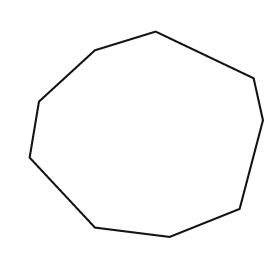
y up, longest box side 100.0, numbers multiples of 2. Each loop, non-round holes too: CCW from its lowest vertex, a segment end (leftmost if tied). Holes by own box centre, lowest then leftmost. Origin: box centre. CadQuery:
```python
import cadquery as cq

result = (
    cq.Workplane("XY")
    .moveTo(10.0, -44.0)
    .lineTo(40.0, -32.0)
    .lineTo(50.0, 6.0)
    .lineTo(46.0, 24.0)
    .lineTo(4.0, 44.0)
    .lineTo(-22.0, 36.0)
    .lineTo(-46.0, 14.0)
    .lineTo(-50.0, -10.0)
    .lineTo(-22.0, -40.0)
    .close()
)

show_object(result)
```